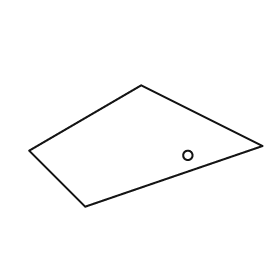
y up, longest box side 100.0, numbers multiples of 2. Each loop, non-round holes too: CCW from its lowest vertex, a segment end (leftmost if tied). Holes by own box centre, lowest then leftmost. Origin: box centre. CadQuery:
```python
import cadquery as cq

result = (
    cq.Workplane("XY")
    .moveTo(-26.0, -26.0)
    .lineTo(50.0, 0.0)
    .lineTo(-2.0, 26.0)
    .lineTo(-50.0, -2.0)
    .close()
    .moveTo(18.0, -4.0)
    .circle(2.0)
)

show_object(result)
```